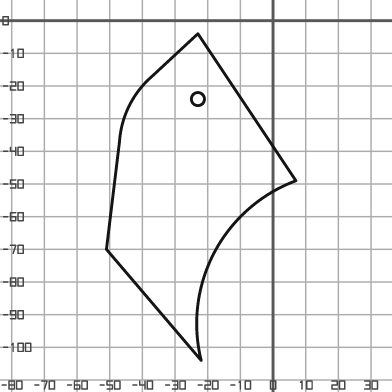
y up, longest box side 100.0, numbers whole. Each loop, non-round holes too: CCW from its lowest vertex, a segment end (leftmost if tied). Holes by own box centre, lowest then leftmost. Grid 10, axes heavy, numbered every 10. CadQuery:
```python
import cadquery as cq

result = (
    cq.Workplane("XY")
    .moveTo(-22.0, -104.0)
    .threePointArc((-18.0, -71.0), (7.0, -49.0))
    .lineTo(-23.0, -4.0)
    .lineTo(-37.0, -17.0)
    .threePointArc((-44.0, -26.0), (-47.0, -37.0))
    .lineTo(-51.0, -70.0)
    .close()
    .moveTo(-23.0, -24.0)
    .circle(2.0)
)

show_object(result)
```